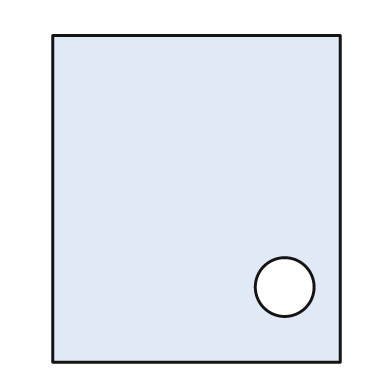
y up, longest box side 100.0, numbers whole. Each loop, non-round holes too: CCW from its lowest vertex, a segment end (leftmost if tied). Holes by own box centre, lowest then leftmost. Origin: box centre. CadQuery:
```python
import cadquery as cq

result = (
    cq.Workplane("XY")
    .moveTo(-44.0, -50.0)
    .lineTo(44.0, -50.0)
    .lineTo(44.0, 50.0)
    .lineTo(-44.0, 50.0)
    .close()
    .moveTo(27.0, -27.0)
    .circle(9.0)
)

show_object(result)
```